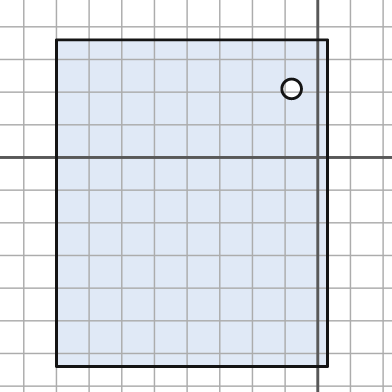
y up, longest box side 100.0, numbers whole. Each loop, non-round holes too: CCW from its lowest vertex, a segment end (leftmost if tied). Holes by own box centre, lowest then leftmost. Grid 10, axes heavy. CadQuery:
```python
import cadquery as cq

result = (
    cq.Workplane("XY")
    .moveTo(-80.0, -64.0)
    .lineTo(3.0, -64.0)
    .lineTo(3.0, 36.0)
    .lineTo(-80.0, 36.0)
    .close()
    .moveTo(-8.0, 21.0)
    .circle(3.0)
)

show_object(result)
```